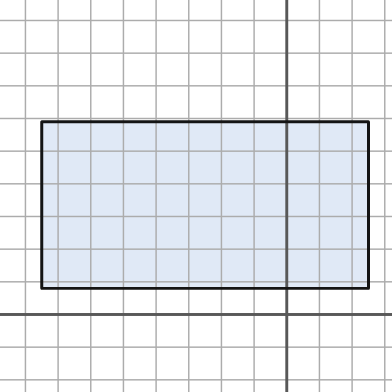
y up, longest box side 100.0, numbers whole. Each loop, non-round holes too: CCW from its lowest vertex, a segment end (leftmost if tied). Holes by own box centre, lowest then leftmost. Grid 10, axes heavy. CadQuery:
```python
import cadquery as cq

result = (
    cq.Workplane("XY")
    .moveTo(-75.0, 8.0)
    .lineTo(25.0, 8.0)
    .lineTo(25.0, 59.0)
    .lineTo(-75.0, 59.0)
    .close()
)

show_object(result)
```